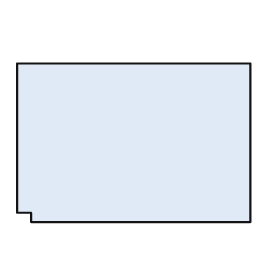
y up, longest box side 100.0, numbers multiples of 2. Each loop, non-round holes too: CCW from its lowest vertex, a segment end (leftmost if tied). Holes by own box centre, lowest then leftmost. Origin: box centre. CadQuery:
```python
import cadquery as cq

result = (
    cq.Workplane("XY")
    .moveTo(-44.0, -34.0)
    .lineTo(50.0, -34.0)
    .lineTo(50.0, 34.0)
    .lineTo(-50.0, 34.0)
    .lineTo(-50.0, -30.0)
    .lineTo(-44.0, -30.0)
    .close()
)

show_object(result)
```